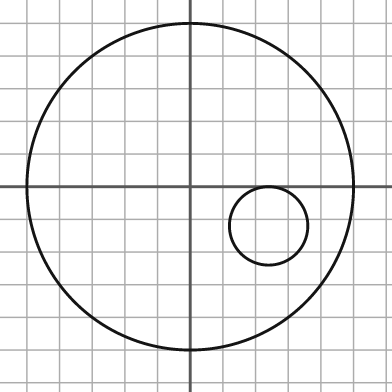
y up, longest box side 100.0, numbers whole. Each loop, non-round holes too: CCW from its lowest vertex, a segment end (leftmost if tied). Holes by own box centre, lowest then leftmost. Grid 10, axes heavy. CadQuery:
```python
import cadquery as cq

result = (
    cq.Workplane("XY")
    .moveTo(0.0, 0.0)
    .circle(50.0)
    .moveTo(24.0, -12.0)
    .circle(12.0)
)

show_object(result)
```